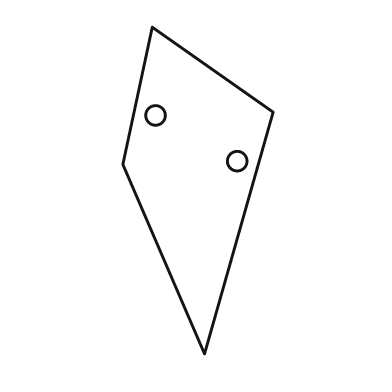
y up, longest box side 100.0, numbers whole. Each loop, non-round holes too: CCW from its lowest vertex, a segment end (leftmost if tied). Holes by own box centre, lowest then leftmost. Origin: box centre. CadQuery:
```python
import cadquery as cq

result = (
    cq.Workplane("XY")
    .moveTo(2.0, -50.0)
    .lineTo(23.0, 24.0)
    .lineTo(-14.0, 50.0)
    .lineTo(-23.0, 8.0)
    .close()
    .moveTo(12.0, 9.0)
    .circle(3.0)
    .moveTo(-13.0, 23.0)
    .circle(3.0)
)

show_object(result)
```